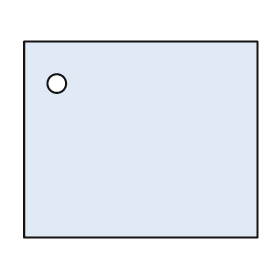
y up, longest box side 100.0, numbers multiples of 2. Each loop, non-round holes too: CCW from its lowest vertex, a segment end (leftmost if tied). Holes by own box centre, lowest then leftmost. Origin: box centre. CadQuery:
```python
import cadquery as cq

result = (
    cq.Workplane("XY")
    .moveTo(-50.0, -42.0)
    .lineTo(50.0, -42.0)
    .lineTo(50.0, 42.0)
    .lineTo(-50.0, 42.0)
    .close()
    .moveTo(-36.0, 24.0)
    .circle(4.0)
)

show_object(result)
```